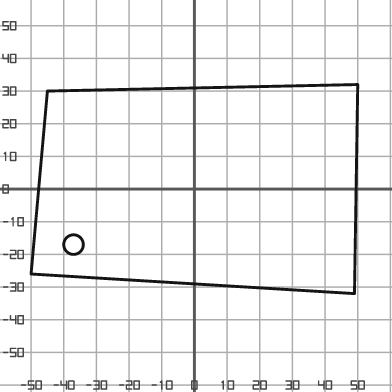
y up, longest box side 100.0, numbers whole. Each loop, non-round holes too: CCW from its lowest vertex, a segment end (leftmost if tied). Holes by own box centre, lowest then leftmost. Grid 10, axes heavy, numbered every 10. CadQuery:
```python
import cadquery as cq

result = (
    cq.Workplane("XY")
    .moveTo(49.0, -32.0)
    .lineTo(50.0, 32.0)
    .lineTo(-45.0, 30.0)
    .lineTo(-50.0, -26.0)
    .close()
    .moveTo(-37.0, -17.0)
    .circle(3.0)
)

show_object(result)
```